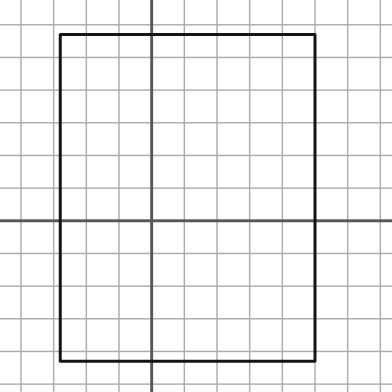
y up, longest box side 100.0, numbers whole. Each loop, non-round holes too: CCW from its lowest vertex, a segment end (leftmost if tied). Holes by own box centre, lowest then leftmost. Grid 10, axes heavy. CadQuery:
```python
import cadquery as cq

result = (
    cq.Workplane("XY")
    .moveTo(-28.0, -43.0)
    .lineTo(50.0, -43.0)
    .lineTo(50.0, 57.0)
    .lineTo(-28.0, 57.0)
    .close()
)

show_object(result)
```